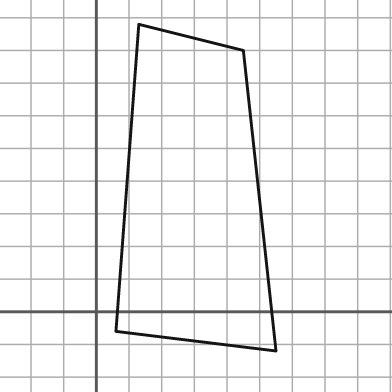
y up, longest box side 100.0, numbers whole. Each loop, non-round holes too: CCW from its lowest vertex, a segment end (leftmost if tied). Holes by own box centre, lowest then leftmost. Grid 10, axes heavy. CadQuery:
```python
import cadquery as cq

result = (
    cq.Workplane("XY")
    .moveTo(55.0, -12.0)
    .lineTo(45.0, 80.0)
    .lineTo(13.0, 88.0)
    .lineTo(6.0, -6.0)
    .close()
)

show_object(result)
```